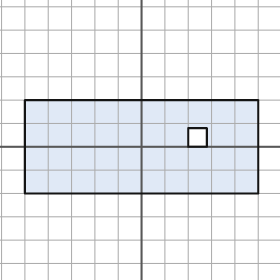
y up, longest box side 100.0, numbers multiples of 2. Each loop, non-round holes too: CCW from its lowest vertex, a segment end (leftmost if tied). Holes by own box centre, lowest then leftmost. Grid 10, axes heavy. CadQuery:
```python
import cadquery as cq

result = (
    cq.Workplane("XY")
    .moveTo(-50.0, -20.0)
    .lineTo(50.0, -20.0)
    .lineTo(50.0, 20.0)
    .lineTo(-50.0, 20.0)
    .close()
    .moveTo(20.0, 0.0)
    .lineTo(28.0, 0.0)
    .lineTo(28.0, 8.0)
    .lineTo(20.0, 8.0)
    .close()
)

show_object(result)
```